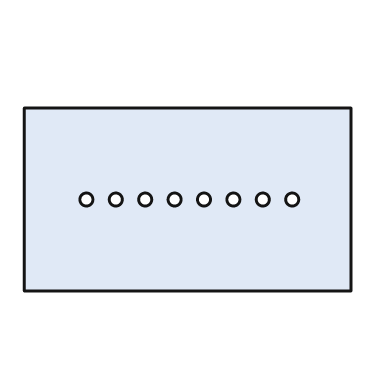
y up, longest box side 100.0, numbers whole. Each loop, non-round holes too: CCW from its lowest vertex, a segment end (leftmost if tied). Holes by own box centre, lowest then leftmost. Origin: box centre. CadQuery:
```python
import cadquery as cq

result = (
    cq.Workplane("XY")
    .moveTo(-50.0, -28.0)
    .lineTo(50.0, -28.0)
    .lineTo(50.0, 28.0)
    .lineTo(-50.0, 28.0)
    .close()
    .moveTo(-31.0, 0.0)
    .circle(2.0)
    .moveTo(-22.0, 0.0)
    .circle(2.0)
    .moveTo(-13.0, 0.0)
    .circle(2.0)
    .moveTo(-4.0, 0.0)
    .circle(2.0)
    .moveTo(5.0, 0.0)
    .circle(2.0)
    .moveTo(14.0, 0.0)
    .circle(2.0)
    .moveTo(23.0, 0.0)
    .circle(2.0)
    .moveTo(32.0, 0.0)
    .circle(2.0)
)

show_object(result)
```